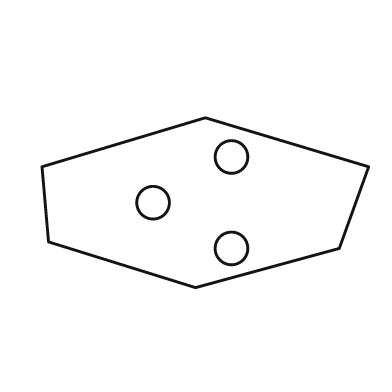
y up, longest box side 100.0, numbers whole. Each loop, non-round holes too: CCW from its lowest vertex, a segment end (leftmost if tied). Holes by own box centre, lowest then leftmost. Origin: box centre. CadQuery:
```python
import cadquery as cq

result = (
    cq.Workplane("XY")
    .moveTo(-3.0, -26.0)
    .lineTo(41.0, -14.0)
    .lineTo(50.0, 11.0)
    .lineTo(0.0, 26.0)
    .lineTo(-50.0, 11.0)
    .lineTo(-48.0, -12.0)
    .close()
    .moveTo(8.0, -14.0)
    .circle(5.0)
    .moveTo(-16.0, 0.0)
    .circle(5.0)
    .moveTo(8.0, 14.0)
    .circle(5.0)
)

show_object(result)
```